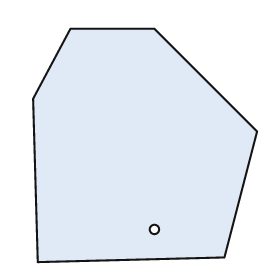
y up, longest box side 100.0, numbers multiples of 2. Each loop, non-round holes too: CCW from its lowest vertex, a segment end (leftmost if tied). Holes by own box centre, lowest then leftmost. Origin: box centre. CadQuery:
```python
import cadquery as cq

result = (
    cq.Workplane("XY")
    .moveTo(-46.0, -50.0)
    .lineTo(34.0, -48.0)
    .lineTo(48.0, 6.0)
    .lineTo(4.0, 50.0)
    .lineTo(-32.0, 50.0)
    .lineTo(-48.0, 20.0)
    .close()
    .moveTo(4.0, -36.0)
    .circle(2.0)
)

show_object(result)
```